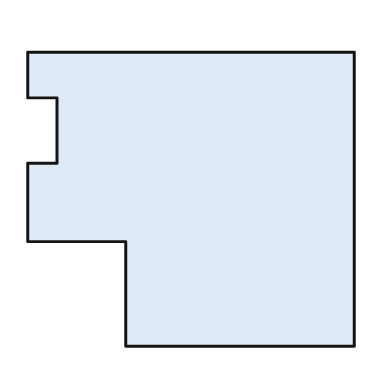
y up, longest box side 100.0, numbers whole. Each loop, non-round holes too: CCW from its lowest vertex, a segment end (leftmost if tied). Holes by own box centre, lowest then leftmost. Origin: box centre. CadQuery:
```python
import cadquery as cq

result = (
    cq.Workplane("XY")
    .moveTo(-20.0, -45.0)
    .lineTo(50.0, -45.0)
    .lineTo(50.0, 45.0)
    .lineTo(-50.0, 45.0)
    .lineTo(-50.0, 31.0)
    .lineTo(-41.0, 31.0)
    .lineTo(-41.0, 11.0)
    .lineTo(-50.0, 11.0)
    .lineTo(-50.0, -13.0)
    .lineTo(-20.0, -13.0)
    .close()
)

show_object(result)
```